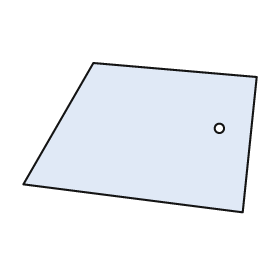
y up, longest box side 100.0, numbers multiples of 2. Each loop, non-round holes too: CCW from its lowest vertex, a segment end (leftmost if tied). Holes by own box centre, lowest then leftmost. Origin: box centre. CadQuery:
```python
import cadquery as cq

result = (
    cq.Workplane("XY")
    .moveTo(44.0, -32.0)
    .lineTo(50.0, 26.0)
    .lineTo(-20.0, 32.0)
    .lineTo(-50.0, -20.0)
    .close()
    .moveTo(34.0, 4.0)
    .circle(2.0)
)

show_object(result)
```